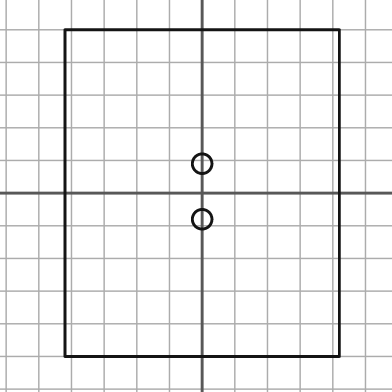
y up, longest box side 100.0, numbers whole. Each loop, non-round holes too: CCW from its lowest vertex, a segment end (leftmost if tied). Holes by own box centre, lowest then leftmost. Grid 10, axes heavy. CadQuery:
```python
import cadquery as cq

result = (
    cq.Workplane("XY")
    .moveTo(-42.0, -50.0)
    .lineTo(42.0, -50.0)
    .lineTo(42.0, 50.0)
    .lineTo(-42.0, 50.0)
    .close()
    .moveTo(0.0, -8.0)
    .circle(3.0)
    .moveTo(0.0, 9.0)
    .circle(3.0)
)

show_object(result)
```